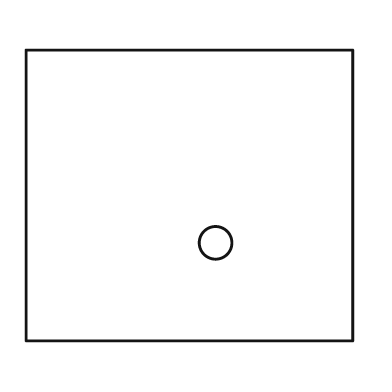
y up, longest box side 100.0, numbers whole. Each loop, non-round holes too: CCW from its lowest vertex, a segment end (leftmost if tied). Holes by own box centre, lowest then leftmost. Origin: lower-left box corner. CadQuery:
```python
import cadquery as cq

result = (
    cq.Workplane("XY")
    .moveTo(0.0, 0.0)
    .lineTo(100.0, 0.0)
    .lineTo(100.0, 89.0)
    .lineTo(0.0, 89.0)
    .close()
    .moveTo(58.0, 30.0)
    .circle(5.0)
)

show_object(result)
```